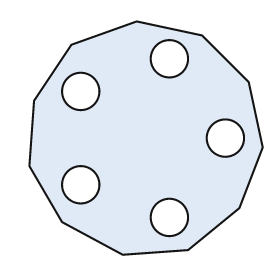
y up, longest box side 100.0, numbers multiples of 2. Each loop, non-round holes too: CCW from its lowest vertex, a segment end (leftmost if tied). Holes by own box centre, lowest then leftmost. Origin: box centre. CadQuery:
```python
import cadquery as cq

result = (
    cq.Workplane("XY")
    .moveTo(-10.0, -50.0)
    .lineTo(18.0, -48.0)
    .lineTo(40.0, -30.0)
    .lineTo(50.0, -4.0)
    .lineTo(44.0, 24.0)
    .lineTo(24.0, 44.0)
    .lineTo(-4.0, 50.0)
    .lineTo(-32.0, 40.0)
    .lineTo(-48.0, 16.0)
    .lineTo(-50.0, -12.0)
    .lineTo(-36.0, -36.0)
    .close()
    .moveTo(10.0, -34.0)
    .circle(8.0)
    .moveTo(-28.0, -20.0)
    .circle(8.0)
    .moveTo(34.0, 0.0)
    .circle(8.0)
    .moveTo(-28.0, 20.0)
    .circle(8.0)
    .moveTo(10.0, 34.0)
    .circle(8.0)
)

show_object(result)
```